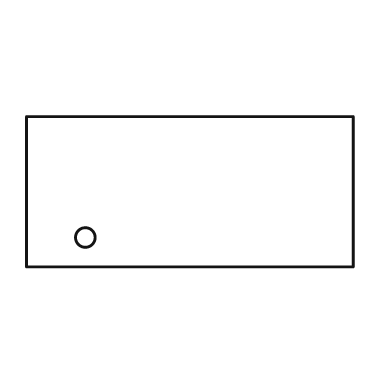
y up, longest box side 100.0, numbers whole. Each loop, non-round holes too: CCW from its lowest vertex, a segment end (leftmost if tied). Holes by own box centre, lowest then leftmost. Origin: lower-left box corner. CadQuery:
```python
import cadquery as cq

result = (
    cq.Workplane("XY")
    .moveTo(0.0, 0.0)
    .lineTo(100.0, 0.0)
    .lineTo(100.0, 46.0)
    .lineTo(0.0, 46.0)
    .close()
    .moveTo(18.0, 9.0)
    .circle(3.0)
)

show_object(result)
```